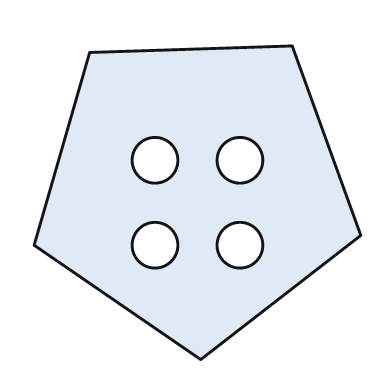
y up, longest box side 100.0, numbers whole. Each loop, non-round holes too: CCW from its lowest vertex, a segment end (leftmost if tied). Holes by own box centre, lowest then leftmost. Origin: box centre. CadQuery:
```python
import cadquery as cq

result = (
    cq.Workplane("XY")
    .moveTo(1.0, -48.0)
    .lineTo(50.0, -10.0)
    .lineTo(29.0, 48.0)
    .lineTo(-33.0, 46.0)
    .lineTo(-50.0, -13.0)
    .close()
    .moveTo(-13.0, -13.0)
    .circle(7.0)
    .moveTo(13.0, -13.0)
    .circle(7.0)
    .moveTo(-13.0, 13.0)
    .circle(7.0)
    .moveTo(13.0, 13.0)
    .circle(7.0)
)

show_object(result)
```